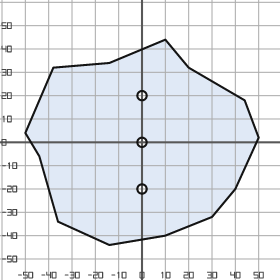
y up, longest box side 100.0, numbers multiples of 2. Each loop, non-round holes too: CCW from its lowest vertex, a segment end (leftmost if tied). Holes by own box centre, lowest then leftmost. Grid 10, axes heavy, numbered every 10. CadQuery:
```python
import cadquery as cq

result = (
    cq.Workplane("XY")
    .moveTo(-14.0, -44.0)
    .lineTo(10.0, -40.0)
    .lineTo(30.0, -32.0)
    .lineTo(40.0, -20.0)
    .lineTo(50.0, 2.0)
    .lineTo(44.0, 18.0)
    .lineTo(20.0, 32.0)
    .lineTo(10.0, 44.0)
    .lineTo(-14.0, 34.0)
    .lineTo(-38.0, 32.0)
    .lineTo(-50.0, 4.0)
    .lineTo(-44.0, -6.0)
    .lineTo(-36.0, -34.0)
    .close()
    .moveTo(0.0, -20.0)
    .circle(2.0)
    .moveTo(0.0, 0.0)
    .circle(2.0)
    .moveTo(0.0, 20.0)
    .circle(2.0)
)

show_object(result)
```